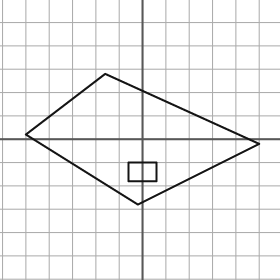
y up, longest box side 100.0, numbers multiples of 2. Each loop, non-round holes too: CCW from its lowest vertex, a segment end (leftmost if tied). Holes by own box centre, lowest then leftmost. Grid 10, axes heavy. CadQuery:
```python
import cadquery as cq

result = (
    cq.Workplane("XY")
    .moveTo(-2.0, -28.0)
    .lineTo(50.0, -2.0)
    .lineTo(-16.0, 28.0)
    .lineTo(-50.0, 2.0)
    .close()
    .moveTo(-6.0, -18.0)
    .lineTo(6.0, -18.0)
    .lineTo(6.0, -10.0)
    .lineTo(-6.0, -10.0)
    .close()
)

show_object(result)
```